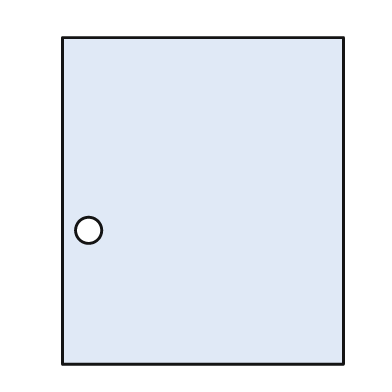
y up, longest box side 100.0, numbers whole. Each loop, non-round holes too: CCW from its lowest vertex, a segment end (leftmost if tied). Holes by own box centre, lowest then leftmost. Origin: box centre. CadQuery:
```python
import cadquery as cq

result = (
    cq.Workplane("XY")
    .moveTo(-43.0, -50.0)
    .lineTo(43.0, -50.0)
    .lineTo(43.0, 50.0)
    .lineTo(-43.0, 50.0)
    .close()
    .moveTo(-35.0, -9.0)
    .circle(4.0)
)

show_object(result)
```